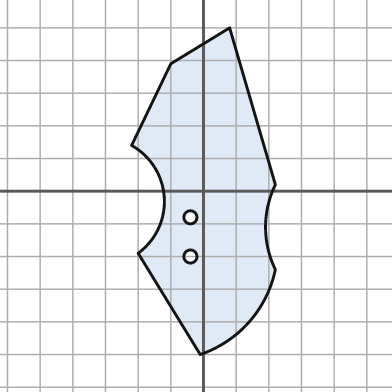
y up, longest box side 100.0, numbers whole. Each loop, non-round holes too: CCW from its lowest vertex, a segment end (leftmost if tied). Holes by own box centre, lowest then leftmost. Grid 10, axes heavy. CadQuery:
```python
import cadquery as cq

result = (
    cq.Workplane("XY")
    .moveTo(-1.0, -50.0)
    .threePointArc((14.0, -40.0), (22.0, -24.0))
    .threePointArc((19.0, -11.0), (22.0, 2.0))
    .lineTo(8.0, 50.0)
    .lineTo(-10.0, 39.0)
    .lineTo(-22.0, 14.0)
    .threePointArc((-12.0, -2.0), (-20.0, -19.0))
    .close()
    .moveTo(-4.0, -20.0)
    .circle(2.0)
    .moveTo(-4.0, -8.0)
    .circle(2.0)
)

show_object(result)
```